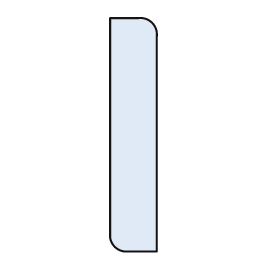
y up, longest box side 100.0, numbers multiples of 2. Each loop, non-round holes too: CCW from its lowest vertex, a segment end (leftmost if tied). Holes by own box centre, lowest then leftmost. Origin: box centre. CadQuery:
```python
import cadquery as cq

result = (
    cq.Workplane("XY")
    .moveTo(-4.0, -50.0)
    .lineTo(10.0, -50.0)
    .lineTo(10.0, 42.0)
    .threePointArc((8.0, 48.0), (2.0, 50.0))
    .lineTo(-10.0, 50.0)
    .lineTo(-10.0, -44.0)
    .threePointArc((-8.0, -48.0), (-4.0, -50.0))
    .close()
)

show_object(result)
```